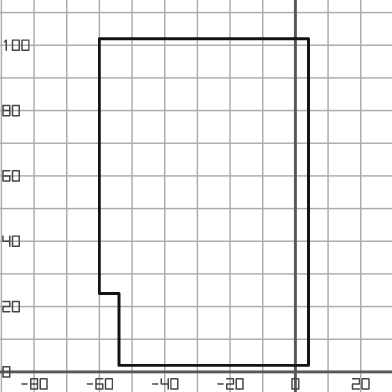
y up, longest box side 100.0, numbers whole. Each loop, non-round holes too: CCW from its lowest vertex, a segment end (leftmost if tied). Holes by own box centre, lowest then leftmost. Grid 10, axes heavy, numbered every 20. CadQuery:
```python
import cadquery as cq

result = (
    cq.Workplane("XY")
    .moveTo(-54.0, 2.0)
    .lineTo(4.0, 2.0)
    .lineTo(4.0, 102.0)
    .lineTo(-60.0, 102.0)
    .lineTo(-60.0, 24.0)
    .lineTo(-54.0, 24.0)
    .close()
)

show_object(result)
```